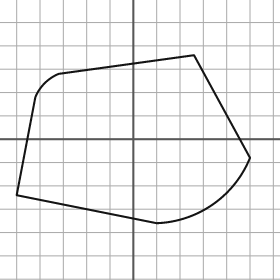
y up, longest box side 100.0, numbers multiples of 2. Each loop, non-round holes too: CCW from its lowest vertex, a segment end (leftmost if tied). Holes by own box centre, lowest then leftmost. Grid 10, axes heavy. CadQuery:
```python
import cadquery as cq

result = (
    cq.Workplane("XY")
    .moveTo(10.0, -36.0)
    .threePointArc((34.0, -28.0), (50.0, -8.0))
    .lineTo(26.0, 36.0)
    .lineTo(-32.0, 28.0)
    .threePointArc((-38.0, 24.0), (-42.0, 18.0))
    .lineTo(-50.0, -24.0)
    .close()
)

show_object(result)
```